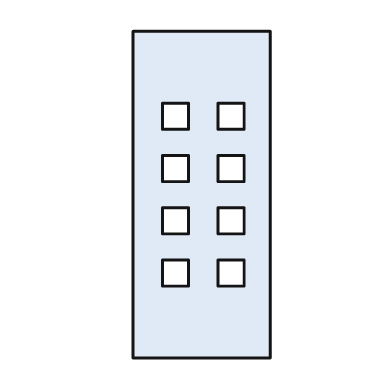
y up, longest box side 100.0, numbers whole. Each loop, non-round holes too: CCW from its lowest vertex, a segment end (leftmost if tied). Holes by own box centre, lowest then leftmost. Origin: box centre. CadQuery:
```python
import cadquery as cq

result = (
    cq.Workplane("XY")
    .moveTo(-21.0, -50.0)
    .lineTo(21.0, -50.0)
    .lineTo(21.0, 50.0)
    .lineTo(-21.0, 50.0)
    .close()
    .moveTo(-12.0, -28.0)
    .lineTo(-4.0, -28.0)
    .lineTo(-4.0, -20.0)
    .lineTo(-12.0, -20.0)
    .close()
    .moveTo(5.0, -28.0)
    .lineTo(13.0, -28.0)
    .lineTo(13.0, -20.0)
    .lineTo(5.0, -20.0)
    .close()
    .moveTo(-12.0, -12.0)
    .lineTo(-4.0, -12.0)
    .lineTo(-4.0, -4.0)
    .lineTo(-12.0, -4.0)
    .close()
    .moveTo(5.0, -12.0)
    .lineTo(13.0, -12.0)
    .lineTo(13.0, -4.0)
    .lineTo(5.0, -4.0)
    .close()
    .moveTo(-12.0, 4.0)
    .lineTo(-4.0, 4.0)
    .lineTo(-4.0, 12.0)
    .lineTo(-12.0, 12.0)
    .close()
    .moveTo(5.0, 4.0)
    .lineTo(13.0, 4.0)
    .lineTo(13.0, 12.0)
    .lineTo(5.0, 12.0)
    .close()
    .moveTo(-12.0, 20.0)
    .lineTo(-4.0, 20.0)
    .lineTo(-4.0, 28.0)
    .lineTo(-12.0, 28.0)
    .close()
    .moveTo(5.0, 20.0)
    .lineTo(13.0, 20.0)
    .lineTo(13.0, 28.0)
    .lineTo(5.0, 28.0)
    .close()
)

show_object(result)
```